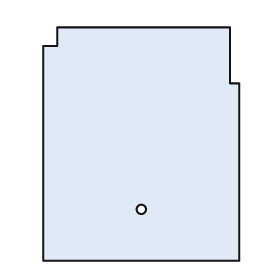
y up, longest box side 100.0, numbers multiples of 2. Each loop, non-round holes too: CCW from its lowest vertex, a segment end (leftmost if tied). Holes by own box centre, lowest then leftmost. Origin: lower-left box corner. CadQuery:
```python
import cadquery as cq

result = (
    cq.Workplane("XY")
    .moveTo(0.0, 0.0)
    .lineTo(84.0, 0.0)
    .lineTo(84.0, 76.0)
    .lineTo(80.0, 76.0)
    .lineTo(80.0, 100.0)
    .lineTo(6.0, 100.0)
    .lineTo(6.0, 92.0)
    .lineTo(0.0, 92.0)
    .close()
    .moveTo(42.0, 22.0)
    .circle(2.0)
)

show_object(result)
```